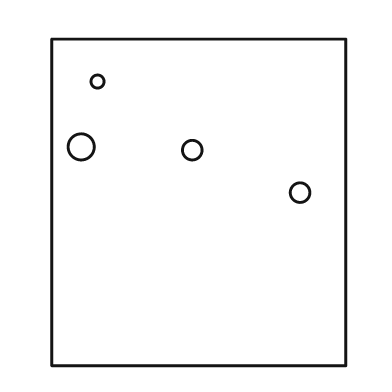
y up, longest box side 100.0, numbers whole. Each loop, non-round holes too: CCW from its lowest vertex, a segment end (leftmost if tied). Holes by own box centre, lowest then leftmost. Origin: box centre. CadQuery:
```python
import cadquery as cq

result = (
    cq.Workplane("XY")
    .moveTo(-45.0, -50.0)
    .lineTo(45.0, -50.0)
    .lineTo(45.0, 50.0)
    .lineTo(-45.0, 50.0)
    .close()
    .moveTo(31.0, 3.0)
    .circle(3.0)
    .moveTo(-2.0, 16.0)
    .circle(3.0)
    .moveTo(-36.0, 17.0)
    .circle(4.0)
    .moveTo(-31.0, 37.0)
    .circle(2.0)
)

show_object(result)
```